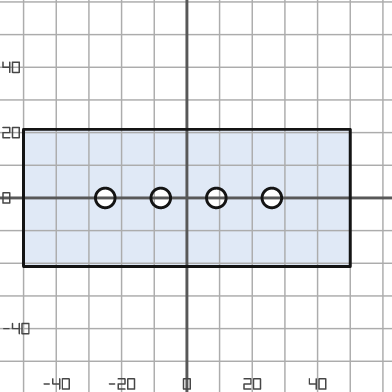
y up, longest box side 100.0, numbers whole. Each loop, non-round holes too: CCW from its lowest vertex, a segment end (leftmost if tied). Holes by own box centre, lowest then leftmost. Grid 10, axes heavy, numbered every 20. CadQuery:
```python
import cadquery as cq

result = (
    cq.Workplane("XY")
    .moveTo(-50.0, -21.0)
    .lineTo(50.0, -21.0)
    .lineTo(50.0, 21.0)
    .lineTo(-50.0, 21.0)
    .close()
    .moveTo(-25.0, 0.0)
    .circle(3.0)
    .moveTo(-8.0, 0.0)
    .circle(3.0)
    .moveTo(9.0, 0.0)
    .circle(3.0)
    .moveTo(26.0, 0.0)
    .circle(3.0)
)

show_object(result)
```